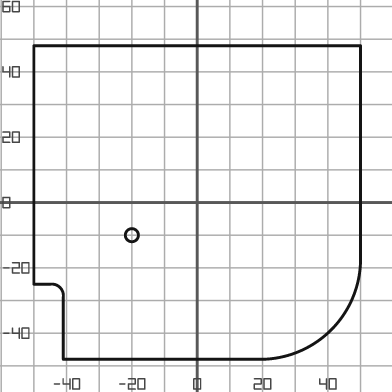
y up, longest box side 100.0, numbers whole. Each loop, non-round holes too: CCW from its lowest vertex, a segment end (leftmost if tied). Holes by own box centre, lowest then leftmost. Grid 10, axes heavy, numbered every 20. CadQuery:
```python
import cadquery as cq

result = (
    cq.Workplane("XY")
    .moveTo(-41.0, -48.0)
    .lineTo(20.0, -48.0)
    .threePointArc((41.0, -39.0), (50.0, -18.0))
    .lineTo(50.0, 48.0)
    .lineTo(-50.0, 48.0)
    .lineTo(-50.0, -25.0)
    .lineTo(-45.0, -25.0)
    .threePointArc((-42.0, -26.0), (-41.0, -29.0))
    .close()
    .moveTo(-20.0, -10.0)
    .circle(2.0)
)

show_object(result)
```